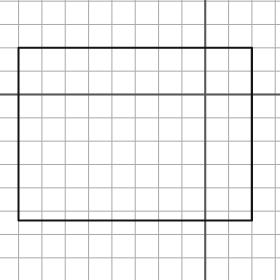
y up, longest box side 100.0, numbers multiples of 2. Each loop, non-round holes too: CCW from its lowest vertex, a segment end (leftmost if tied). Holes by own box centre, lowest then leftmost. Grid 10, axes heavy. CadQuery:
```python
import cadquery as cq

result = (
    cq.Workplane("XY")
    .moveTo(-80.0, -54.0)
    .lineTo(20.0, -54.0)
    .lineTo(20.0, 20.0)
    .lineTo(-80.0, 20.0)
    .close()
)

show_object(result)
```